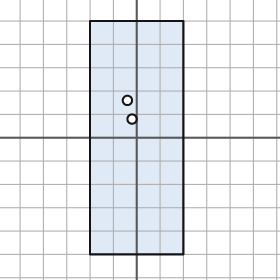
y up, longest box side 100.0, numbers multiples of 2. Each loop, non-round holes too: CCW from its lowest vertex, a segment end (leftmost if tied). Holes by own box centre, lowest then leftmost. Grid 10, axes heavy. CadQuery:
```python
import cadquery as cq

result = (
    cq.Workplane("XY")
    .moveTo(-20.0, -50.0)
    .lineTo(20.0, -50.0)
    .lineTo(20.0, 50.0)
    .lineTo(-20.0, 50.0)
    .close()
    .moveTo(-2.0, 8.0)
    .circle(2.0)
    .moveTo(-4.0, 16.0)
    .circle(2.0)
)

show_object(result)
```